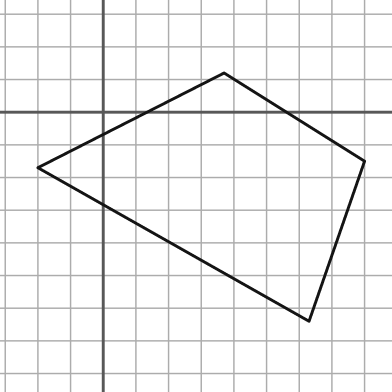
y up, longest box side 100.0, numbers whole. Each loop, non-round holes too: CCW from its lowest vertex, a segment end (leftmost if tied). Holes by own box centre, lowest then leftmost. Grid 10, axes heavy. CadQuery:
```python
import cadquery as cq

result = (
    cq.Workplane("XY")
    .moveTo(63.0, -64.0)
    .lineTo(80.0, -15.0)
    .lineTo(37.0, 12.0)
    .lineTo(-20.0, -17.0)
    .close()
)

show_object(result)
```